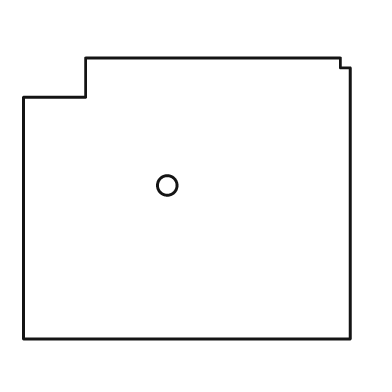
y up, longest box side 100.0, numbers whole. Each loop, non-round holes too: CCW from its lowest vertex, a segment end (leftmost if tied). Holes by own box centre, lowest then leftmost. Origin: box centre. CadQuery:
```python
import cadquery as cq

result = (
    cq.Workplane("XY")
    .moveTo(-50.0, -43.0)
    .lineTo(50.0, -43.0)
    .lineTo(50.0, 40.0)
    .lineTo(47.0, 40.0)
    .lineTo(47.0, 43.0)
    .lineTo(-31.0, 43.0)
    .lineTo(-31.0, 31.0)
    .lineTo(-50.0, 31.0)
    .close()
    .moveTo(-6.0, 4.0)
    .circle(3.0)
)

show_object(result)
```